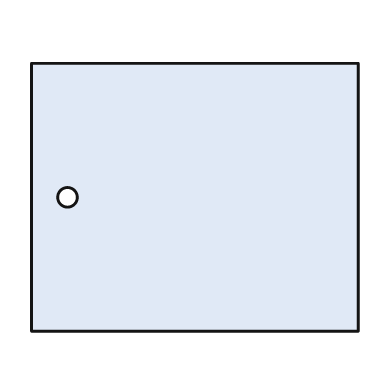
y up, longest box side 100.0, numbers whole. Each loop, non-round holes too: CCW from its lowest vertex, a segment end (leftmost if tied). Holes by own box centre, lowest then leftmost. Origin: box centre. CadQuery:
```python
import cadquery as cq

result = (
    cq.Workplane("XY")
    .moveTo(-50.0, -41.0)
    .lineTo(50.0, -41.0)
    .lineTo(50.0, 41.0)
    .lineTo(-50.0, 41.0)
    .close()
    .moveTo(-39.0, 0.0)
    .circle(3.0)
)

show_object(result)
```